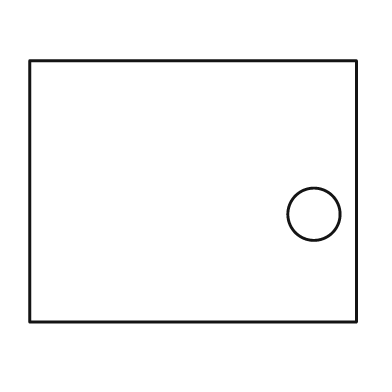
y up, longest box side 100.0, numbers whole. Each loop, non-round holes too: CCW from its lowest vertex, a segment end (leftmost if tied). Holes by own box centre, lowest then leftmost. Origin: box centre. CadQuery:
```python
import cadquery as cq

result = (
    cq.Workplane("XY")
    .moveTo(-50.0, -40.0)
    .lineTo(50.0, -40.0)
    .lineTo(50.0, 40.0)
    .lineTo(-50.0, 40.0)
    .close()
    .moveTo(37.0, -7.0)
    .circle(8.0)
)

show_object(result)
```